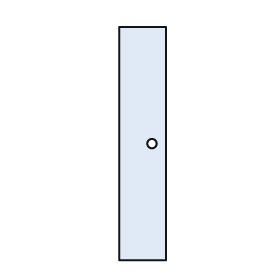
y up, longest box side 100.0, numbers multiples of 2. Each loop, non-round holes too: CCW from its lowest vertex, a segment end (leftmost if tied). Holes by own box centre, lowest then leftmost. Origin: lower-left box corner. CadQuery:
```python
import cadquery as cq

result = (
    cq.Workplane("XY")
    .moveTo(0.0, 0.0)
    .lineTo(20.0, 0.0)
    .lineTo(20.0, 100.0)
    .lineTo(0.0, 100.0)
    .close()
    .moveTo(14.0, 50.0)
    .circle(2.0)
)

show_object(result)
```